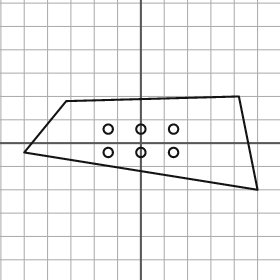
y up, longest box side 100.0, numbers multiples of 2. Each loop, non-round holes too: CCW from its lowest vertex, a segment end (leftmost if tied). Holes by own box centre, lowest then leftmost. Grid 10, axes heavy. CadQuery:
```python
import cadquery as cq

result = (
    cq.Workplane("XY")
    .moveTo(50.0, -20.0)
    .lineTo(42.0, 20.0)
    .lineTo(-32.0, 18.0)
    .lineTo(-50.0, -4.0)
    .close()
    .moveTo(-14.0, -4.0)
    .circle(2.0)
    .moveTo(0.0, -4.0)
    .circle(2.0)
    .moveTo(14.0, -4.0)
    .circle(2.0)
    .moveTo(-14.0, 6.0)
    .circle(2.0)
    .moveTo(0.0, 6.0)
    .circle(2.0)
    .moveTo(14.0, 6.0)
    .circle(2.0)
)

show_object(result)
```